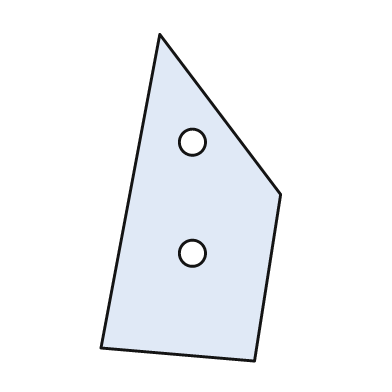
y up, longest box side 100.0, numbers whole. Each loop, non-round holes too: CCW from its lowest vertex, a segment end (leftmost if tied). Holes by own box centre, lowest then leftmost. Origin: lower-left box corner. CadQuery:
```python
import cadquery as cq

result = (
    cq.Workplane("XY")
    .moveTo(47.0, 0.0)
    .lineTo(55.0, 51.0)
    .lineTo(18.0, 100.0)
    .lineTo(0.0, 4.0)
    .close()
    .moveTo(28.0, 33.0)
    .circle(4.0)
    .moveTo(28.0, 67.0)
    .circle(4.0)
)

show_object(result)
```